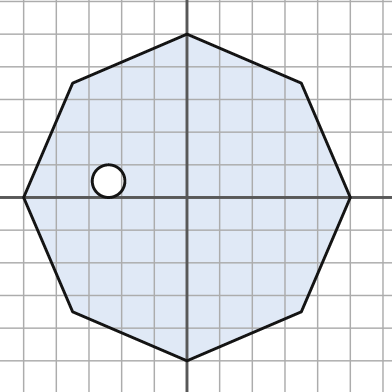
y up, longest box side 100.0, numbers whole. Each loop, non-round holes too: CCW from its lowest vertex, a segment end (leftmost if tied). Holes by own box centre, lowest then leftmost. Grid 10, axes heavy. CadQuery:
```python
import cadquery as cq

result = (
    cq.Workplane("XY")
    .moveTo(0.0, -50.0)
    .lineTo(35.0, -35.0)
    .lineTo(50.0, 0.0)
    .lineTo(35.0, 35.0)
    .lineTo(0.0, 50.0)
    .lineTo(-35.0, 35.0)
    .lineTo(-50.0, 0.0)
    .lineTo(-35.0, -35.0)
    .close()
    .moveTo(-24.0, 5.0)
    .circle(5.0)
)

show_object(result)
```